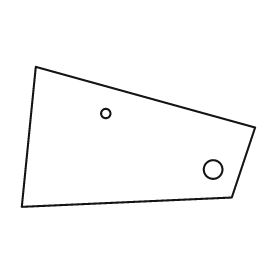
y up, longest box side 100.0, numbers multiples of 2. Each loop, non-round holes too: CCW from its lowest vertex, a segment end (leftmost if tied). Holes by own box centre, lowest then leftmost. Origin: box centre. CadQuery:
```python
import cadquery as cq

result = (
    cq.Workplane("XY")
    .moveTo(-50.0, -30.0)
    .lineTo(40.0, -26.0)
    .lineTo(50.0, 4.0)
    .lineTo(-44.0, 30.0)
    .close()
    .moveTo(32.0, -14.0)
    .circle(4.0)
    .moveTo(-14.0, 10.0)
    .circle(2.0)
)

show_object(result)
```